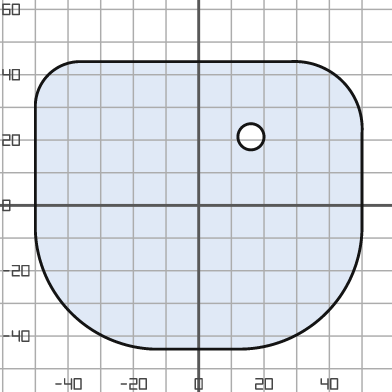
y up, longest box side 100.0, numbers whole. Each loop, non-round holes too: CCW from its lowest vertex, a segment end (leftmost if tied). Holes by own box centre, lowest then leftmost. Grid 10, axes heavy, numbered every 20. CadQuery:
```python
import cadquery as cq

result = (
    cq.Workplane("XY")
    .moveTo(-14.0, -44.0)
    .lineTo(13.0, -44.0)
    .threePointArc((39.0, -33.0), (50.0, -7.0))
    .lineTo(50.0, 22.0)
    .threePointArc((44.0, 38.0), (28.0, 44.0))
    .lineTo(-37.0, 44.0)
    .threePointArc((-46.0, 40.0), (-50.0, 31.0))
    .lineTo(-50.0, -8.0)
    .threePointArc((-39.0, -33.0), (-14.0, -44.0))
    .close()
    .moveTo(16.0, 21.0)
    .circle(4.0)
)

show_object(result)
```